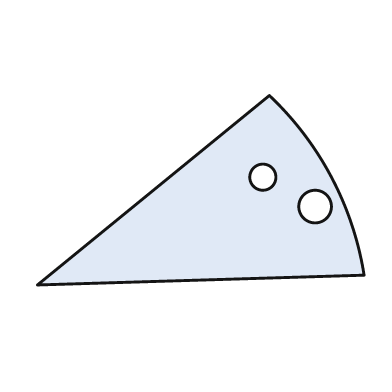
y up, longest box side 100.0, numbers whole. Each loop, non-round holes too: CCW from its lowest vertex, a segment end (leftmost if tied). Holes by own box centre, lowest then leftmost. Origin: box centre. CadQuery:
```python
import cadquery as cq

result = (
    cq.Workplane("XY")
    .moveTo(-50.0, -29.0)
    .lineTo(50.0, -26.0)
    .threePointArc((40.0, 4.0), (21.0, 29.0))
    .close()
    .moveTo(35.0, -5.0)
    .circle(5.0)
    .moveTo(19.0, 4.0)
    .circle(4.0)
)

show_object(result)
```